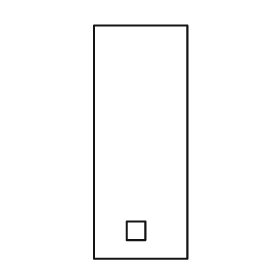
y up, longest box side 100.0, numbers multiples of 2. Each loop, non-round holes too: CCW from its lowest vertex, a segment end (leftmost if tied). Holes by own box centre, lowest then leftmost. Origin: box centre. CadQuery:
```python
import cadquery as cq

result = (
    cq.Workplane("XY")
    .moveTo(-20.0, -50.0)
    .lineTo(20.0, -50.0)
    .lineTo(20.0, 50.0)
    .lineTo(-20.0, 50.0)
    .close()
    .moveTo(-6.0, -42.0)
    .lineTo(2.0, -42.0)
    .lineTo(2.0, -34.0)
    .lineTo(-6.0, -34.0)
    .close()
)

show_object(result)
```